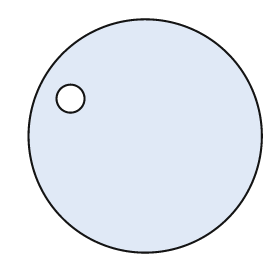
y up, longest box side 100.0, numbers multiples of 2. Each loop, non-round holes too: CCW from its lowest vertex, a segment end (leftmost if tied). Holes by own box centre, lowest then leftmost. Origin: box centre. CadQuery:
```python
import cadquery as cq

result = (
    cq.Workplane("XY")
    .moveTo(0.0, 0.0)
    .circle(50.0)
    .moveTo(-32.0, 16.0)
    .circle(6.0)
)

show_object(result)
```